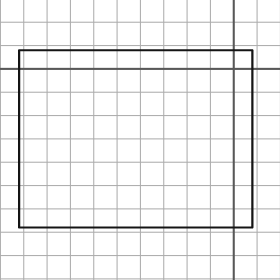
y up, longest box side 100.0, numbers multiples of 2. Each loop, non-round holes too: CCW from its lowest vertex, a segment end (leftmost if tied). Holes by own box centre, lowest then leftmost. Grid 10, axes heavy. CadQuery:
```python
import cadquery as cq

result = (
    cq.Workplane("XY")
    .moveTo(-92.0, -68.0)
    .lineTo(8.0, -68.0)
    .lineTo(8.0, 8.0)
    .lineTo(-92.0, 8.0)
    .close()
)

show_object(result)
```